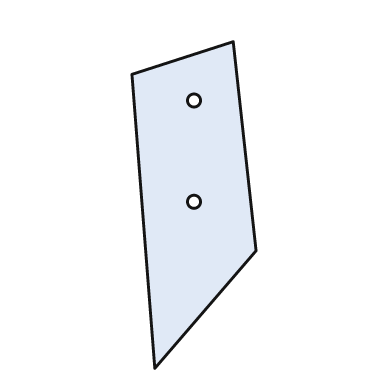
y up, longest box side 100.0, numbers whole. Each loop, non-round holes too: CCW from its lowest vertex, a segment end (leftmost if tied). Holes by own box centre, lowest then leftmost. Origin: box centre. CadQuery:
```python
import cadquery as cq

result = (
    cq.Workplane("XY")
    .moveTo(-12.0, -50.0)
    .lineTo(19.0, -14.0)
    .lineTo(12.0, 50.0)
    .lineTo(-19.0, 40.0)
    .close()
    .moveTo(0.0, 1.0)
    .circle(2.0)
    .moveTo(0.0, 32.0)
    .circle(2.0)
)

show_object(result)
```